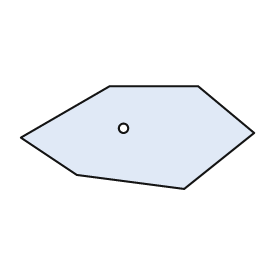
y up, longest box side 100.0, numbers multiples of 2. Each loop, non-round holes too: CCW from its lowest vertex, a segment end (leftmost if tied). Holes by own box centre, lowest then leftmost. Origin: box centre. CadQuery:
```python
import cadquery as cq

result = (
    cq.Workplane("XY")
    .moveTo(20.0, -22.0)
    .lineTo(50.0, 2.0)
    .lineTo(26.0, 22.0)
    .lineTo(-12.0, 22.0)
    .lineTo(-50.0, 0.0)
    .lineTo(-26.0, -16.0)
    .close()
    .moveTo(-6.0, 4.0)
    .circle(2.0)
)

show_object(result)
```